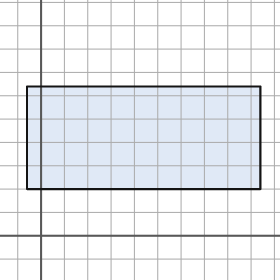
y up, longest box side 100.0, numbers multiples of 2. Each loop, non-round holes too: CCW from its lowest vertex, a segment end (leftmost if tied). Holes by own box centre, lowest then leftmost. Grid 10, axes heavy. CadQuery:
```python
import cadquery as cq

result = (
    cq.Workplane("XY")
    .moveTo(-6.0, 20.0)
    .lineTo(94.0, 20.0)
    .lineTo(94.0, 64.0)
    .lineTo(-6.0, 64.0)
    .close()
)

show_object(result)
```